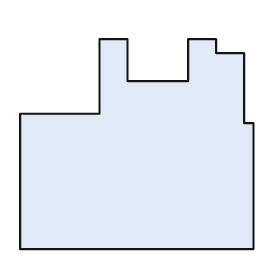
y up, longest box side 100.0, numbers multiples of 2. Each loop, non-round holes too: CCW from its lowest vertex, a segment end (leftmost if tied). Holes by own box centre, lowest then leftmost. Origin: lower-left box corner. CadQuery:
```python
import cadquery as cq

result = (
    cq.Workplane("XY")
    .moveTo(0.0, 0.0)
    .lineTo(100.0, 0.0)
    .lineTo(100.0, 54.0)
    .lineTo(96.0, 54.0)
    .lineTo(96.0, 84.0)
    .lineTo(84.0, 84.0)
    .lineTo(84.0, 90.0)
    .lineTo(72.0, 90.0)
    .lineTo(72.0, 72.0)
    .lineTo(46.0, 72.0)
    .lineTo(46.0, 90.0)
    .lineTo(34.0, 90.0)
    .lineTo(34.0, 58.0)
    .lineTo(0.0, 58.0)
    .close()
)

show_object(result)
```